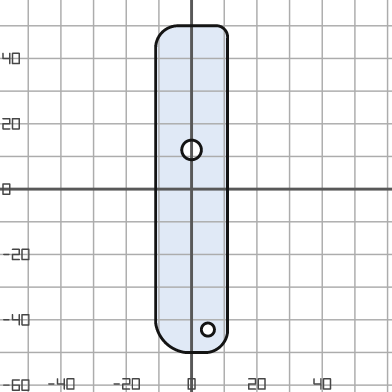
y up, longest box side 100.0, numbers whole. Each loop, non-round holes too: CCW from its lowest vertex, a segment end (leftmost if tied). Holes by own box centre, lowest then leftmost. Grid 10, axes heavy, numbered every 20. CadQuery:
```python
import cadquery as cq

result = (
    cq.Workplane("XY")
    .moveTo(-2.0, -50.0)
    .lineTo(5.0, -50.0)
    .threePointArc((9.0, -48.0), (11.0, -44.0))
    .lineTo(11.0, 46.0)
    .threePointArc((10.0, 49.0), (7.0, 50.0))
    .lineTo(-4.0, 50.0)
    .threePointArc((-9.0, 48.0), (-11.0, 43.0))
    .lineTo(-11.0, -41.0)
    .threePointArc((-8.0, -47.0), (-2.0, -50.0))
    .close()
    .moveTo(5.0, -43.0)
    .circle(2.0)
    .moveTo(0.0, 12.0)
    .circle(3.0)
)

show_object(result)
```